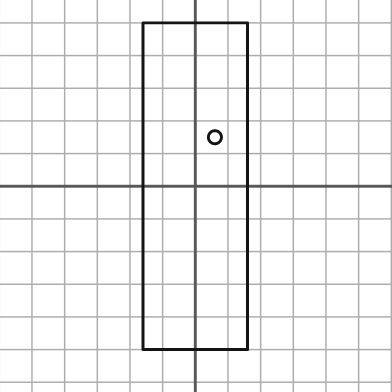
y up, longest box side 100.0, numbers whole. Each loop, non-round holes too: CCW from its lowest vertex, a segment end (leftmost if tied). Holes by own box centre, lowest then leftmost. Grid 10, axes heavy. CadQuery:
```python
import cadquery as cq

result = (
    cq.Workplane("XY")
    .moveTo(-16.0, -50.0)
    .lineTo(16.0, -50.0)
    .lineTo(16.0, 50.0)
    .lineTo(-16.0, 50.0)
    .close()
    .moveTo(6.0, 15.0)
    .circle(2.0)
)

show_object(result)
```